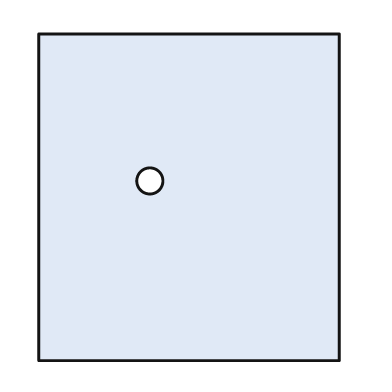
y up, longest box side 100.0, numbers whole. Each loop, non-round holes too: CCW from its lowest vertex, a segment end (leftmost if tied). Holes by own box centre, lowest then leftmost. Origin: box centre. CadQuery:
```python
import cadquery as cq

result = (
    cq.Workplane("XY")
    .moveTo(-46.0, -50.0)
    .lineTo(46.0, -50.0)
    .lineTo(46.0, 50.0)
    .lineTo(-46.0, 50.0)
    .close()
    .moveTo(-12.0, 5.0)
    .circle(4.0)
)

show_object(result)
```